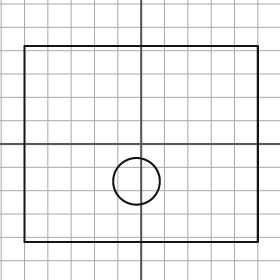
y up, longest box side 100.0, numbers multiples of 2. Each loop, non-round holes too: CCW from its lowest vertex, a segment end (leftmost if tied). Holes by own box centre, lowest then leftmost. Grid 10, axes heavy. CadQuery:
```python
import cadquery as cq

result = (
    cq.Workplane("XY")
    .moveTo(-50.0, -42.0)
    .lineTo(50.0, -42.0)
    .lineTo(50.0, 42.0)
    .lineTo(-50.0, 42.0)
    .close()
    .moveTo(-2.0, -16.0)
    .circle(10.0)
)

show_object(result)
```